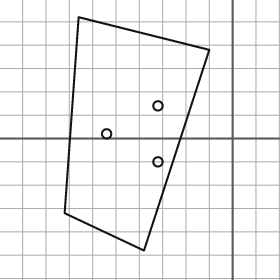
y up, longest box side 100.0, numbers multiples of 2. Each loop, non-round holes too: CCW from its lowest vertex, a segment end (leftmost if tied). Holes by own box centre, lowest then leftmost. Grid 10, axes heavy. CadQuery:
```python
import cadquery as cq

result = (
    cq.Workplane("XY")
    .moveTo(-38.0, -48.0)
    .lineTo(-10.0, 38.0)
    .lineTo(-66.0, 52.0)
    .lineTo(-72.0, -32.0)
    .close()
    .moveTo(-32.0, -10.0)
    .circle(2.0)
    .moveTo(-54.0, 2.0)
    .circle(2.0)
    .moveTo(-32.0, 14.0)
    .circle(2.0)
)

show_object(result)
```